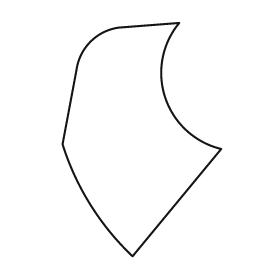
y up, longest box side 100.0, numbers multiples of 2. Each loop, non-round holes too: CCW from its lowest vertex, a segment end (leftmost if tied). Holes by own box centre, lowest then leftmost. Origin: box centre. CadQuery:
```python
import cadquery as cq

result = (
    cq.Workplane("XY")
    .moveTo(-4.0, -50.0)
    .lineTo(34.0, -4.0)
    .threePointArc((10.0, 18.0), (16.0, 50.0))
    .lineTo(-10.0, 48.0)
    .threePointArc((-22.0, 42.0), (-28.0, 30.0))
    .lineTo(-34.0, -2.0)
    .threePointArc((-22.0, -28.0), (-4.0, -50.0))
    .close()
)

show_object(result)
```